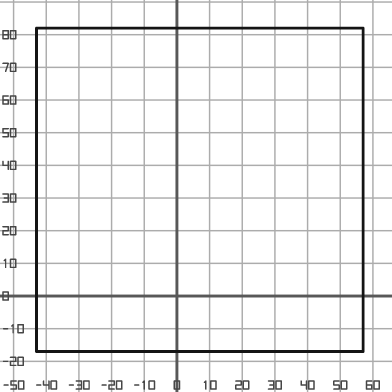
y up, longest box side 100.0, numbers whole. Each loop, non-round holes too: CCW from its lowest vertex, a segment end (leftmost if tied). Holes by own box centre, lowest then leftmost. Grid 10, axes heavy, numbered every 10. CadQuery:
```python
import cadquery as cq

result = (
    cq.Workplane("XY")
    .moveTo(-43.0, -17.0)
    .lineTo(57.0, -17.0)
    .lineTo(57.0, 82.0)
    .lineTo(-43.0, 82.0)
    .close()
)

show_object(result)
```